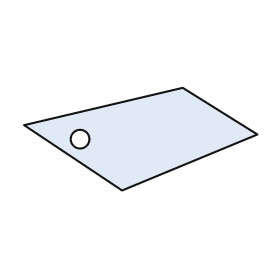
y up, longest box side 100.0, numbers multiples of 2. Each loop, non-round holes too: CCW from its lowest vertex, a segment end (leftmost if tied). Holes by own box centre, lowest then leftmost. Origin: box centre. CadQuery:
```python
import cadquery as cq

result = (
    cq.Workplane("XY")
    .moveTo(-8.0, -22.0)
    .lineTo(50.0, 2.0)
    .lineTo(18.0, 22.0)
    .lineTo(-50.0, 6.0)
    .close()
    .moveTo(-26.0, 0.0)
    .circle(4.0)
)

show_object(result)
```